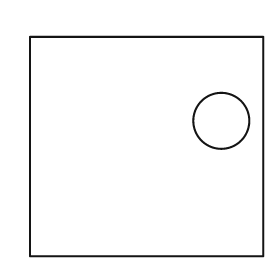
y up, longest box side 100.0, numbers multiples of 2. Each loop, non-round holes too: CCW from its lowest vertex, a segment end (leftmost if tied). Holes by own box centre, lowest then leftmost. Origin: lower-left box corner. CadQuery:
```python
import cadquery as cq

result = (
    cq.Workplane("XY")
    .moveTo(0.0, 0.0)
    .lineTo(100.0, 0.0)
    .lineTo(100.0, 94.0)
    .lineTo(0.0, 94.0)
    .close()
    .moveTo(82.0, 58.0)
    .circle(12.0)
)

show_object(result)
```